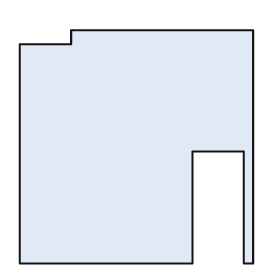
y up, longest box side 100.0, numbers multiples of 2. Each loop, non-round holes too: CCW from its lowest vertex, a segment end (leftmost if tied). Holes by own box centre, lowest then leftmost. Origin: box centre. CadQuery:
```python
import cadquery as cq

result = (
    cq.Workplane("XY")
    .moveTo(-50.0, -50.0)
    .lineTo(24.0, -50.0)
    .lineTo(24.0, -2.0)
    .lineTo(46.0, -2.0)
    .lineTo(46.0, -50.0)
    .lineTo(50.0, -50.0)
    .lineTo(50.0, 50.0)
    .lineTo(-28.0, 50.0)
    .lineTo(-28.0, 44.0)
    .lineTo(-50.0, 44.0)
    .close()
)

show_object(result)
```